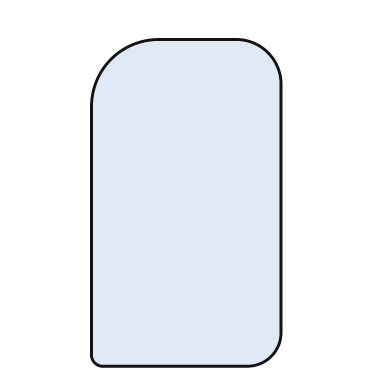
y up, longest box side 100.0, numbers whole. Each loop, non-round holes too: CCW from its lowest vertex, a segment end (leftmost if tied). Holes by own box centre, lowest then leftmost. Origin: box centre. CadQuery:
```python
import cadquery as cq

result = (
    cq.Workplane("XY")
    .moveTo(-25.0, -50.0)
    .lineTo(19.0, -50.0)
    .threePointArc((26.0, -47.0), (29.0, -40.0))
    .lineTo(29.0, 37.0)
    .threePointArc((25.0, 46.0), (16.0, 50.0))
    .lineTo(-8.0, 50.0)
    .threePointArc((-23.0, 44.0), (-29.0, 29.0))
    .lineTo(-29.0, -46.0)
    .threePointArc((-28.0, -49.0), (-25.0, -50.0))
    .close()
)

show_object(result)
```